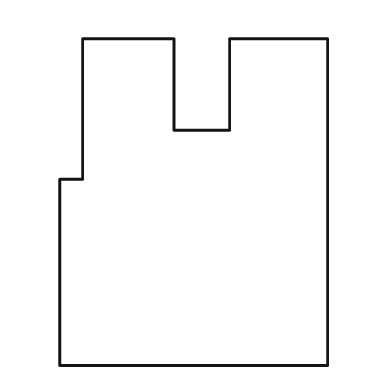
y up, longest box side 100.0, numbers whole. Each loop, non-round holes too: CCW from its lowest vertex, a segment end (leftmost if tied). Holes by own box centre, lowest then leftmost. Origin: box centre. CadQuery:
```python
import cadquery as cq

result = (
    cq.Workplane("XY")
    .moveTo(-41.0, -50.0)
    .lineTo(41.0, -50.0)
    .lineTo(41.0, 50.0)
    .lineTo(11.0, 50.0)
    .lineTo(11.0, 22.0)
    .lineTo(-6.0, 22.0)
    .lineTo(-6.0, 50.0)
    .lineTo(-34.0, 50.0)
    .lineTo(-34.0, 7.0)
    .lineTo(-41.0, 7.0)
    .close()
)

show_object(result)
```